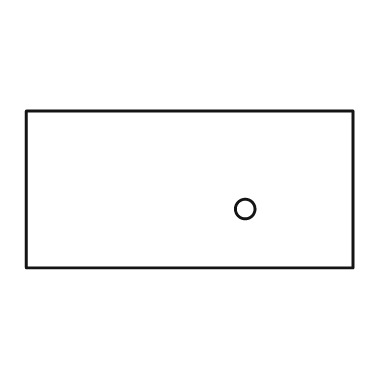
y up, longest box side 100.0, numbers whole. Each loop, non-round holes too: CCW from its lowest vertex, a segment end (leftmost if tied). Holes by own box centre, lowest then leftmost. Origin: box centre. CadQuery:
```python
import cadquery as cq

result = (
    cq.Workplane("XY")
    .moveTo(-50.0, -24.0)
    .lineTo(50.0, -24.0)
    .lineTo(50.0, 24.0)
    .lineTo(-50.0, 24.0)
    .close()
    .moveTo(17.0, -6.0)
    .circle(3.0)
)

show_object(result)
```